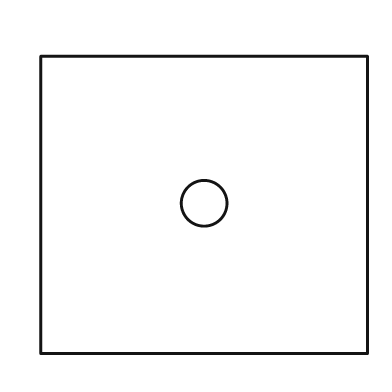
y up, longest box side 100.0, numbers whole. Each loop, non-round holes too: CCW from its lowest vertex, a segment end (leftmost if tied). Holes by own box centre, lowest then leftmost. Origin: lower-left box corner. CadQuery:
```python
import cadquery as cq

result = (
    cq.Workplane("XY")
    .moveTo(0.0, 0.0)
    .lineTo(100.0, 0.0)
    .lineTo(100.0, 91.0)
    .lineTo(0.0, 91.0)
    .close()
    .moveTo(50.0, 46.0)
    .circle(7.0)
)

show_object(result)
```